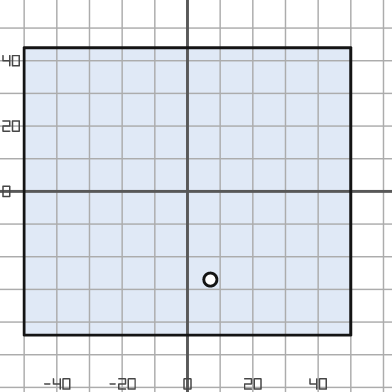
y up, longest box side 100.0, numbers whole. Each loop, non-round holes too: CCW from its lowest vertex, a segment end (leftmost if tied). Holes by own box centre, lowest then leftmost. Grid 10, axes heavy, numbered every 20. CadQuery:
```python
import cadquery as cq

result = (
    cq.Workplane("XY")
    .moveTo(-50.0, -44.0)
    .lineTo(50.0, -44.0)
    .lineTo(50.0, 44.0)
    .lineTo(-50.0, 44.0)
    .close()
    .moveTo(7.0, -27.0)
    .circle(2.0)
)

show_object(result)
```